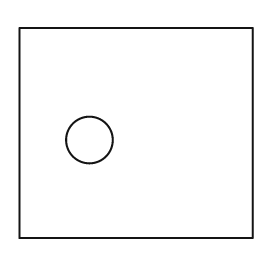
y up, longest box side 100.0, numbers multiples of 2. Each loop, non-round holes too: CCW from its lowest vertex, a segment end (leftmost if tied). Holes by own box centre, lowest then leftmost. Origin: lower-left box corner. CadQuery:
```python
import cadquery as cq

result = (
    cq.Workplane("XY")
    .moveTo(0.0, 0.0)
    .lineTo(100.0, 0.0)
    .lineTo(100.0, 90.0)
    .lineTo(0.0, 90.0)
    .close()
    .moveTo(30.0, 42.0)
    .circle(10.0)
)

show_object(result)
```